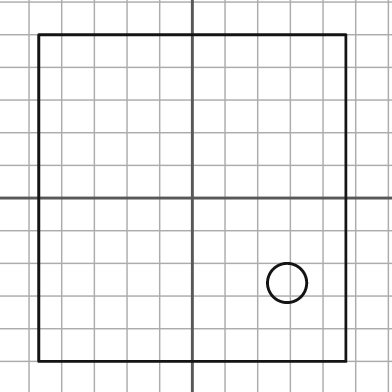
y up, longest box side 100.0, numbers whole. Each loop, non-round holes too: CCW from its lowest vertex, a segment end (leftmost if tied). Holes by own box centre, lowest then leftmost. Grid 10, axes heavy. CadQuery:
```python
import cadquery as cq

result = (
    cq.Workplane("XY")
    .moveTo(-47.0, -50.0)
    .lineTo(47.0, -50.0)
    .lineTo(47.0, 50.0)
    .lineTo(-47.0, 50.0)
    .close()
    .moveTo(29.0, -26.0)
    .circle(6.0)
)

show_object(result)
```